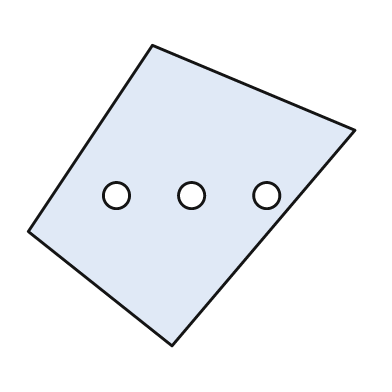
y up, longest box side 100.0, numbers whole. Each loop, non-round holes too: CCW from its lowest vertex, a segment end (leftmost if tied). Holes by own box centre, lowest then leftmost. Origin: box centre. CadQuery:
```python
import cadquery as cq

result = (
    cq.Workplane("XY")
    .moveTo(-6.0, -46.0)
    .lineTo(50.0, 20.0)
    .lineTo(-12.0, 46.0)
    .lineTo(-50.0, -11.0)
    .close()
    .moveTo(-23.0, 0.0)
    .circle(4.0)
    .moveTo(0.0, 0.0)
    .circle(4.0)
    .moveTo(23.0, 0.0)
    .circle(4.0)
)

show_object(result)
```